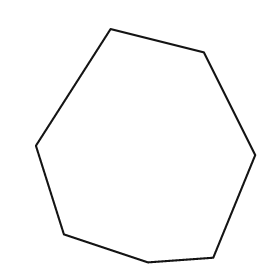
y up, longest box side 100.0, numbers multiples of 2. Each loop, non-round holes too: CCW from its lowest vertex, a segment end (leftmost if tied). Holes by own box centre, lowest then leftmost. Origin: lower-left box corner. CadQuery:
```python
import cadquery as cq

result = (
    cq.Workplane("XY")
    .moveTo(48.0, 0.0)
    .lineTo(76.0, 2.0)
    .lineTo(94.0, 46.0)
    .lineTo(72.0, 90.0)
    .lineTo(32.0, 100.0)
    .lineTo(0.0, 50.0)
    .lineTo(12.0, 12.0)
    .close()
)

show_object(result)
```